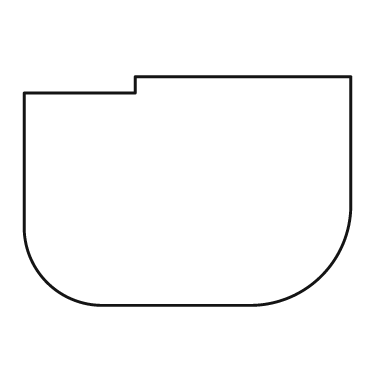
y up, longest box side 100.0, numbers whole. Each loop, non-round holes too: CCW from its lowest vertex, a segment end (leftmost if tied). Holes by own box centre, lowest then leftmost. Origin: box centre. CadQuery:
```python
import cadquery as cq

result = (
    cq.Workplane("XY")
    .moveTo(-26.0, -35.0)
    .lineTo(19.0, -35.0)
    .threePointArc((41.0, -26.0), (50.0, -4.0))
    .lineTo(50.0, 35.0)
    .lineTo(-16.0, 35.0)
    .lineTo(-16.0, 30.0)
    .lineTo(-50.0, 30.0)
    .lineTo(-50.0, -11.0)
    .threePointArc((-43.0, -28.0), (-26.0, -35.0))
    .close()
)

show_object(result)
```